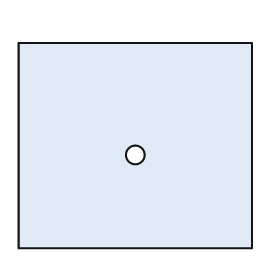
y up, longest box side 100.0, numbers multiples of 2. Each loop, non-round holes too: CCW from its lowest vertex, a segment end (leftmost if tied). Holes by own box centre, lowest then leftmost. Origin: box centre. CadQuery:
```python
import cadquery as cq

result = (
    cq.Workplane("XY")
    .moveTo(-50.0, -44.0)
    .lineTo(50.0, -44.0)
    .lineTo(50.0, 44.0)
    .lineTo(-50.0, 44.0)
    .close()
    .moveTo(0.0, -4.0)
    .circle(4.0)
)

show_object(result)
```